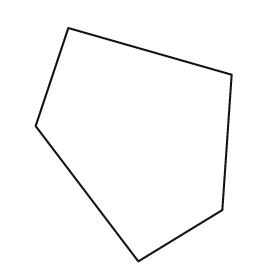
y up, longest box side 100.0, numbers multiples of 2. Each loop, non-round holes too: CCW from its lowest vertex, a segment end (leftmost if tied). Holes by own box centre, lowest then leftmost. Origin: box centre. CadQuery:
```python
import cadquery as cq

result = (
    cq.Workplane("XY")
    .moveTo(2.0, -50.0)
    .lineTo(38.0, -28.0)
    .lineTo(42.0, 30.0)
    .lineTo(-28.0, 50.0)
    .lineTo(-42.0, 8.0)
    .close()
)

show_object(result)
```